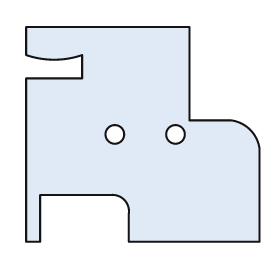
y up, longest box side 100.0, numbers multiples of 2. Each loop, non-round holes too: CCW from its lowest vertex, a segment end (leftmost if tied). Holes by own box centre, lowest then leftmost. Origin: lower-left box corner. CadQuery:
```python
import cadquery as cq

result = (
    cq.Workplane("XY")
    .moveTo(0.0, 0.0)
    .lineTo(6.0, 0.0)
    .lineTo(6.0, 20.0)
    .lineTo(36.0, 20.0)
    .threePointArc((42.0, 18.0), (44.0, 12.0))
    .lineTo(44.0, 0.0)
    .lineTo(100.0, 0.0)
    .lineTo(100.0, 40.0)
    .threePointArc((96.0, 48.0), (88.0, 52.0))
    .lineTo(70.0, 52.0)
    .lineTo(70.0, 92.0)
    .lineTo(0.0, 92.0)
    .lineTo(0.0, 80.0)
    .threePointArc((12.0, 78.0), (24.0, 80.0))
    .lineTo(24.0, 70.0)
    .lineTo(0.0, 70.0)
    .close()
    .moveTo(38.0, 46.0)
    .circle(4.0)
    .moveTo(64.0, 46.0)
    .circle(4.0)
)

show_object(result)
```